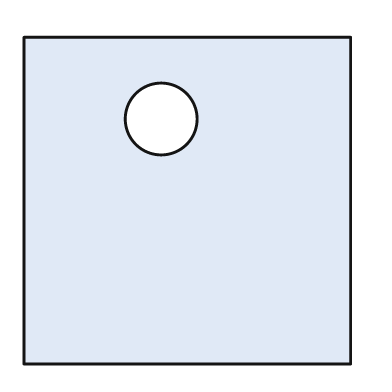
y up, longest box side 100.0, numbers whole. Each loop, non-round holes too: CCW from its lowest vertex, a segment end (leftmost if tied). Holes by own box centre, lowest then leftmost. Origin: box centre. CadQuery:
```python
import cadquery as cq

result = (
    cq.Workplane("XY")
    .moveTo(-50.0, -50.0)
    .lineTo(50.0, -50.0)
    .lineTo(50.0, 50.0)
    .lineTo(-50.0, 50.0)
    .close()
    .moveTo(-8.0, 25.0)
    .circle(11.0)
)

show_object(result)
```